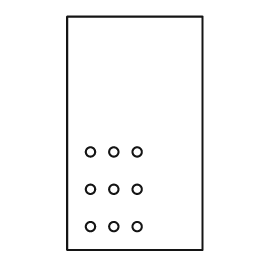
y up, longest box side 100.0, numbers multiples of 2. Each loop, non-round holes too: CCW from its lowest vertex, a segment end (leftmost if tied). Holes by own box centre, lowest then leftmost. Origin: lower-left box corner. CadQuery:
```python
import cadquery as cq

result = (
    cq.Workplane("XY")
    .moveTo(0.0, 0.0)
    .lineTo(58.0, 0.0)
    .lineTo(58.0, 100.0)
    .lineTo(0.0, 100.0)
    .close()
    .moveTo(10.0, 10.0)
    .circle(2.0)
    .moveTo(20.0, 10.0)
    .circle(2.0)
    .moveTo(30.0, 10.0)
    .circle(2.0)
    .moveTo(10.0, 26.0)
    .circle(2.0)
    .moveTo(20.0, 26.0)
    .circle(2.0)
    .moveTo(30.0, 26.0)
    .circle(2.0)
    .moveTo(10.0, 42.0)
    .circle(2.0)
    .moveTo(20.0, 42.0)
    .circle(2.0)
    .moveTo(30.0, 42.0)
    .circle(2.0)
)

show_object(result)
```